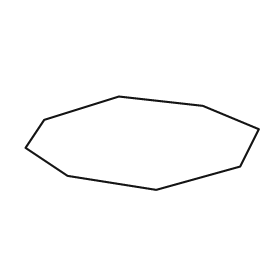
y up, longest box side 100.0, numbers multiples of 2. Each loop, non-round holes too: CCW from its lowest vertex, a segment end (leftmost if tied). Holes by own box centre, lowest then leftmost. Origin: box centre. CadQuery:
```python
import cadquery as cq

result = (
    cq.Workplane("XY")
    .moveTo(6.0, -20.0)
    .lineTo(42.0, -10.0)
    .lineTo(50.0, 6.0)
    .lineTo(26.0, 16.0)
    .lineTo(-10.0, 20.0)
    .lineTo(-42.0, 10.0)
    .lineTo(-50.0, -2.0)
    .lineTo(-32.0, -14.0)
    .close()
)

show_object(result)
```